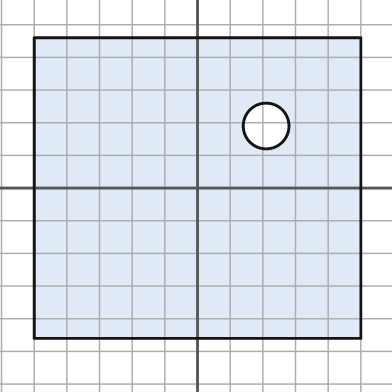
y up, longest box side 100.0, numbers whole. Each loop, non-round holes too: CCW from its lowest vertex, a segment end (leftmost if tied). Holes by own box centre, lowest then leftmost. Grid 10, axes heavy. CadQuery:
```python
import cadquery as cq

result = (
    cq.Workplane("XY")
    .moveTo(-50.0, -46.0)
    .lineTo(50.0, -46.0)
    .lineTo(50.0, 46.0)
    .lineTo(-50.0, 46.0)
    .close()
    .moveTo(21.0, 19.0)
    .circle(7.0)
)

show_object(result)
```